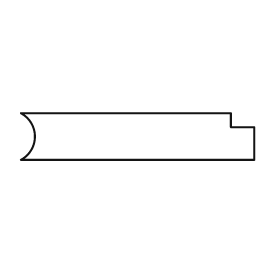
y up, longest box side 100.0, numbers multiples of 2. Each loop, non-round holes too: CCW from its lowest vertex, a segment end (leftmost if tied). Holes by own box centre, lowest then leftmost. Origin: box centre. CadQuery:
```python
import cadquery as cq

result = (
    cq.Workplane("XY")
    .moveTo(-50.0, -10.0)
    .lineTo(50.0, -10.0)
    .lineTo(50.0, 4.0)
    .lineTo(40.0, 4.0)
    .lineTo(40.0, 10.0)
    .lineTo(-50.0, 10.0)
    .threePointArc((-44.0, 0.0), (-50.0, -10.0))
    .close()
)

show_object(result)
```